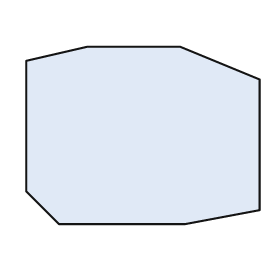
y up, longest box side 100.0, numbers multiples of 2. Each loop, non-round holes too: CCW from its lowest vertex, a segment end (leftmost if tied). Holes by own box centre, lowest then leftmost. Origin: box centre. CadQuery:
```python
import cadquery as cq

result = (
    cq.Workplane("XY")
    .moveTo(-36.0, -38.0)
    .lineTo(18.0, -38.0)
    .lineTo(50.0, -32.0)
    .lineTo(50.0, 24.0)
    .lineTo(16.0, 38.0)
    .lineTo(-24.0, 38.0)
    .lineTo(-50.0, 32.0)
    .lineTo(-50.0, -24.0)
    .close()
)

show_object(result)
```